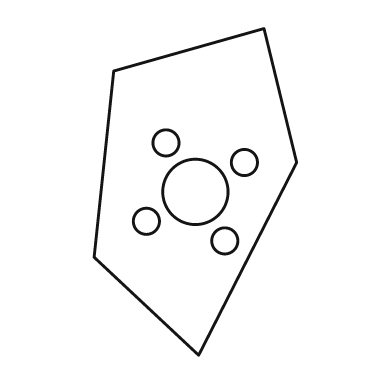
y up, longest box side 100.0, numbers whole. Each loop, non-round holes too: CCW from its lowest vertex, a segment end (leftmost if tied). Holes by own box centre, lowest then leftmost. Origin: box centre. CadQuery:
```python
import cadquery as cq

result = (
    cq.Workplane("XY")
    .moveTo(1.0, -50.0)
    .lineTo(31.0, 9.0)
    .lineTo(21.0, 50.0)
    .lineTo(-25.0, 37.0)
    .lineTo(-31.0, -20.0)
    .close()
    .moveTo(9.0, -15.0)
    .circle(4.0)
    .moveTo(-15.0, -9.0)
    .circle(4.0)
    .moveTo(0.0, 0.0)
    .circle(10.0)
    .moveTo(15.0, 9.0)
    .circle(4.0)
    .moveTo(-9.0, 15.0)
    .circle(4.0)
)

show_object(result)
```